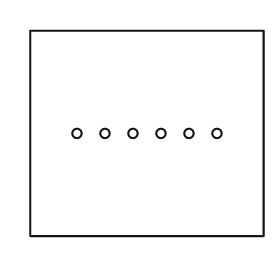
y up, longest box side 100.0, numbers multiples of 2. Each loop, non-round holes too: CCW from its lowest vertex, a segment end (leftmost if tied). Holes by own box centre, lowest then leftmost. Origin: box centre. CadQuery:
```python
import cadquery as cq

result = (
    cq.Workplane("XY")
    .moveTo(-50.0, -44.0)
    .lineTo(50.0, -44.0)
    .lineTo(50.0, 44.0)
    .lineTo(-50.0, 44.0)
    .close()
    .moveTo(-30.0, 0.0)
    .circle(2.0)
    .moveTo(-18.0, 0.0)
    .circle(2.0)
    .moveTo(-6.0, 0.0)
    .circle(2.0)
    .moveTo(6.0, 0.0)
    .circle(2.0)
    .moveTo(18.0, 0.0)
    .circle(2.0)
    .moveTo(30.0, 0.0)
    .circle(2.0)
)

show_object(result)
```